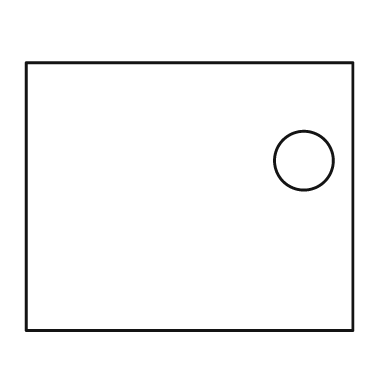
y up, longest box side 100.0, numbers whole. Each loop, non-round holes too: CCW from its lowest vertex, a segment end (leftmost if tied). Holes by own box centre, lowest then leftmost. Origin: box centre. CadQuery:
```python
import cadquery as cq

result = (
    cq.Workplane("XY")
    .moveTo(-50.0, -41.0)
    .lineTo(50.0, -41.0)
    .lineTo(50.0, 41.0)
    .lineTo(-50.0, 41.0)
    .close()
    .moveTo(35.0, 11.0)
    .circle(9.0)
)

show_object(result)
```